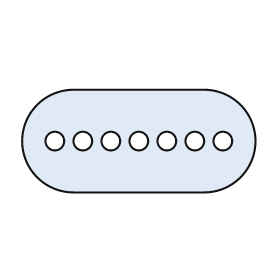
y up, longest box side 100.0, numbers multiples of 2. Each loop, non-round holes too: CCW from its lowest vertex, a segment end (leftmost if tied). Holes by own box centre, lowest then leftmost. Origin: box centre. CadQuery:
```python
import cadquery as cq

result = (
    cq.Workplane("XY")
    .moveTo(-28.0, -22.0)
    .lineTo(28.0, -22.0)
    .threePointArc((50.0, 0.0), (28.0, 22.0))
    .lineTo(-28.0, 22.0)
    .threePointArc((-50.0, 0.0), (-28.0, -22.0))
    .close()
    .moveTo(-36.0, 0.0)
    .circle(4.0)
    .moveTo(-24.0, 0.0)
    .circle(4.0)
    .moveTo(-12.0, 0.0)
    .circle(4.0)
    .moveTo(0.0, 0.0)
    .circle(4.0)
    .moveTo(12.0, 0.0)
    .circle(4.0)
    .moveTo(24.0, 0.0)
    .circle(4.0)
    .moveTo(36.0, 0.0)
    .circle(4.0)
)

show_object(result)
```